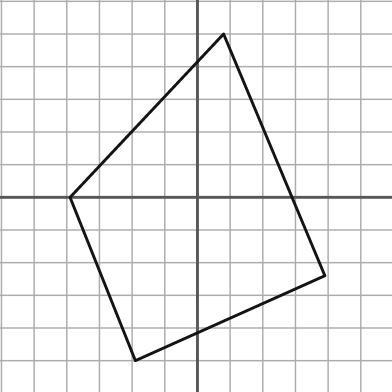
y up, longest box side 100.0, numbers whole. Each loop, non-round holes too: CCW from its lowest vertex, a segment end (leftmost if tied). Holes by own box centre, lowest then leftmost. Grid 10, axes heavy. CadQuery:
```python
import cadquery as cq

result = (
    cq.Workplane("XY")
    .moveTo(-19.0, -50.0)
    .lineTo(39.0, -24.0)
    .lineTo(8.0, 50.0)
    .lineTo(-39.0, 0.0)
    .close()
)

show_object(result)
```